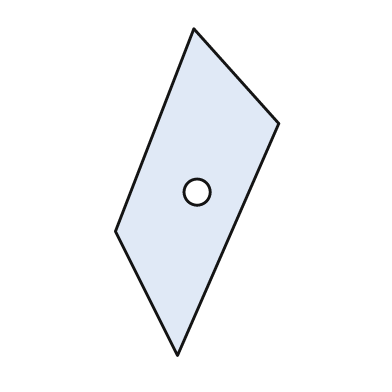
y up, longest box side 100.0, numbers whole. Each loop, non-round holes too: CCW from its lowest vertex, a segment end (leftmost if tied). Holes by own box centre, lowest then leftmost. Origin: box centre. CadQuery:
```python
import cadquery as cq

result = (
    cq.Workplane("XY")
    .moveTo(-6.0, -50.0)
    .lineTo(25.0, 21.0)
    .lineTo(-1.0, 50.0)
    .lineTo(-25.0, -12.0)
    .close()
    .moveTo(0.0, 0.0)
    .circle(4.0)
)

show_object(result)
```